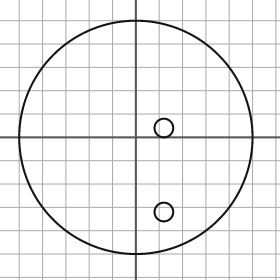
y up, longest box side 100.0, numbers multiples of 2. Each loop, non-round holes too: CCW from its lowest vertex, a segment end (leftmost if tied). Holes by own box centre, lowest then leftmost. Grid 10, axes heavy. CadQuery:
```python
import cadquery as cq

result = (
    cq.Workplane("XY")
    .moveTo(0.0, 0.0)
    .circle(50.0)
    .moveTo(12.0, -32.0)
    .circle(4.0)
    .moveTo(12.0, 4.0)
    .circle(4.0)
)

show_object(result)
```